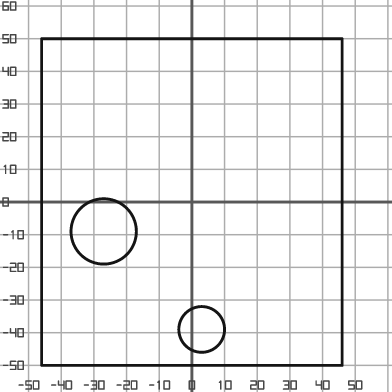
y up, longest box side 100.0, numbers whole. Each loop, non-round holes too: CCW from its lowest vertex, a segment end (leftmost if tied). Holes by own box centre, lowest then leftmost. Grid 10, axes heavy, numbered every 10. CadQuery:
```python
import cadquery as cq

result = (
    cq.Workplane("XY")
    .moveTo(-46.0, -50.0)
    .lineTo(46.0, -50.0)
    .lineTo(46.0, 50.0)
    .lineTo(-46.0, 50.0)
    .close()
    .moveTo(3.0, -39.0)
    .circle(7.0)
    .moveTo(-27.0, -9.0)
    .circle(10.0)
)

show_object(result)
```